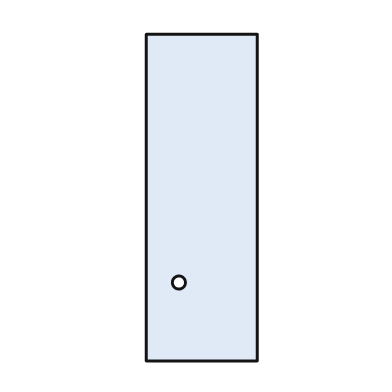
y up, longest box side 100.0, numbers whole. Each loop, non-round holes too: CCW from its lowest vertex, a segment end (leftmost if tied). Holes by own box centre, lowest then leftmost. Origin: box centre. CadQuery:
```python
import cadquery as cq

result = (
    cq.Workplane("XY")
    .moveTo(-17.0, -50.0)
    .lineTo(17.0, -50.0)
    .lineTo(17.0, 50.0)
    .lineTo(-17.0, 50.0)
    .close()
    .moveTo(-7.0, -26.0)
    .circle(2.0)
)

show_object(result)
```